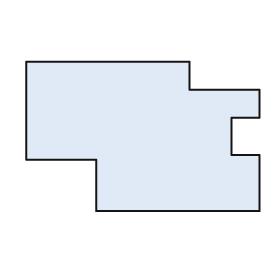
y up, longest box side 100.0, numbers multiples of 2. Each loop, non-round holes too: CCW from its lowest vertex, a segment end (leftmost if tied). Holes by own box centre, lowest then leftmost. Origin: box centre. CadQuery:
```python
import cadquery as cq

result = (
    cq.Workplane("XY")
    .moveTo(-20.0, -32.0)
    .lineTo(50.0, -32.0)
    .lineTo(50.0, -8.0)
    .lineTo(38.0, -8.0)
    .lineTo(38.0, 8.0)
    .lineTo(50.0, 8.0)
    .lineTo(50.0, 20.0)
    .lineTo(20.0, 20.0)
    .lineTo(20.0, 32.0)
    .lineTo(-50.0, 32.0)
    .lineTo(-50.0, -10.0)
    .lineTo(-20.0, -10.0)
    .close()
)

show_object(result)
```